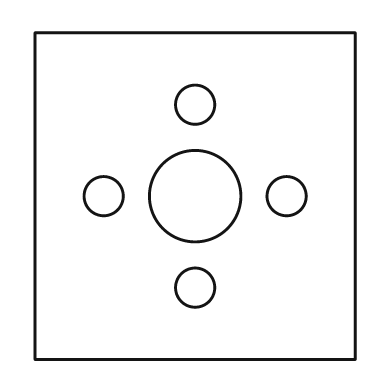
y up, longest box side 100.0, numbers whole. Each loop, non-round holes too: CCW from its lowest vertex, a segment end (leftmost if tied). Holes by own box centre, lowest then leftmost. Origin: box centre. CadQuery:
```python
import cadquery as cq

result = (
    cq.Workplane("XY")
    .moveTo(-49.0, -50.0)
    .lineTo(49.0, -50.0)
    .lineTo(49.0, 50.0)
    .lineTo(-49.0, 50.0)
    .close()
    .moveTo(0.0, -28.0)
    .circle(6.0)
    .moveTo(-28.0, 0.0)
    .circle(6.0)
    .moveTo(0.0, 0.0)
    .circle(14.0)
    .moveTo(28.0, 0.0)
    .circle(6.0)
    .moveTo(0.0, 28.0)
    .circle(6.0)
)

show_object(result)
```